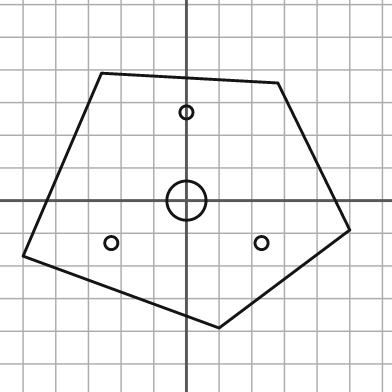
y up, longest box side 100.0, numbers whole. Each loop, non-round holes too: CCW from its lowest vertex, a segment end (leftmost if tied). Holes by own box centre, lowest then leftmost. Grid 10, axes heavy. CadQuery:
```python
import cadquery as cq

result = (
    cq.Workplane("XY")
    .moveTo(10.0, -39.0)
    .lineTo(50.0, -9.0)
    .lineTo(28.0, 36.0)
    .lineTo(-26.0, 39.0)
    .lineTo(-50.0, -17.0)
    .close()
    .moveTo(-23.0, -13.0)
    .circle(2.0)
    .moveTo(23.0, -13.0)
    .circle(2.0)
    .moveTo(0.0, 0.0)
    .circle(6.0)
    .moveTo(0.0, 27.0)
    .circle(2.0)
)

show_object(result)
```